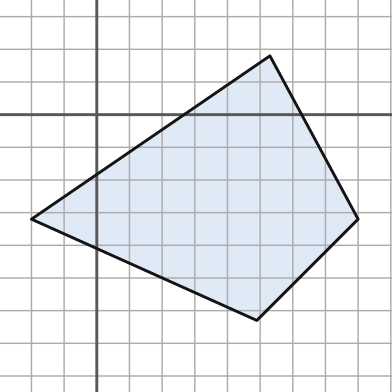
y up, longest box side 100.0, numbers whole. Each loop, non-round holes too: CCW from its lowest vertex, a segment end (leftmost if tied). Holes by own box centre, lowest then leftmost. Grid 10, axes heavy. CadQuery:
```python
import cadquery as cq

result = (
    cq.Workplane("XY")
    .moveTo(49.0, -63.0)
    .lineTo(80.0, -32.0)
    .lineTo(53.0, 18.0)
    .lineTo(-20.0, -32.0)
    .close()
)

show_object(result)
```